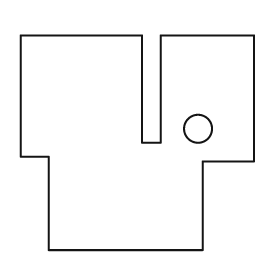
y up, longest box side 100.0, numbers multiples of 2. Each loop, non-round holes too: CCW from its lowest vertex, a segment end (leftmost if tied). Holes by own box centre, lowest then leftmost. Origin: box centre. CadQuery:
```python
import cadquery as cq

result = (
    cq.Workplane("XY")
    .moveTo(-38.0, -46.0)
    .lineTo(28.0, -46.0)
    .lineTo(28.0, -8.0)
    .lineTo(50.0, -8.0)
    .lineTo(50.0, 46.0)
    .lineTo(10.0, 46.0)
    .lineTo(10.0, 0.0)
    .lineTo(2.0, 0.0)
    .lineTo(2.0, 46.0)
    .lineTo(-50.0, 46.0)
    .lineTo(-50.0, -6.0)
    .lineTo(-38.0, -6.0)
    .close()
    .moveTo(26.0, 6.0)
    .circle(6.0)
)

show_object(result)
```